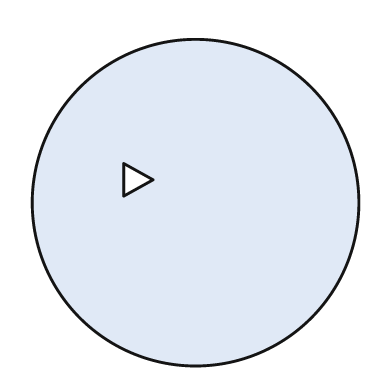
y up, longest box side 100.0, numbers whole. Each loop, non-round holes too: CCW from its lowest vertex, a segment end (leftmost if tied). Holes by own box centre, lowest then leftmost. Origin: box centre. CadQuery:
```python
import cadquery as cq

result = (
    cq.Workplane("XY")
    .moveTo(0.0, 0.0)
    .circle(50.0)
    .moveTo(-22.0, 2.0)
    .lineTo(-13.0, 7.0)
    .lineTo(-22.0, 12.0)
    .close()
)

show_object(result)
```